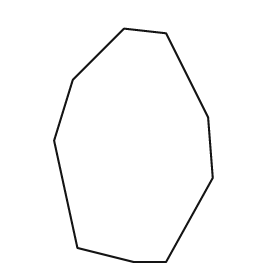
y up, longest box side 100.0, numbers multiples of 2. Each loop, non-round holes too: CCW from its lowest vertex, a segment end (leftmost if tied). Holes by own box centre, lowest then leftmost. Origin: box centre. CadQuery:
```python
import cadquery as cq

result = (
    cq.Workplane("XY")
    .moveTo(0.0, -50.0)
    .lineTo(14.0, -50.0)
    .lineTo(34.0, -14.0)
    .lineTo(32.0, 12.0)
    .lineTo(14.0, 48.0)
    .lineTo(-4.0, 50.0)
    .lineTo(-26.0, 28.0)
    .lineTo(-34.0, 2.0)
    .lineTo(-24.0, -44.0)
    .close()
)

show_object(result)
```